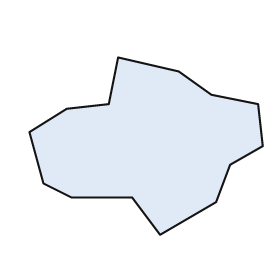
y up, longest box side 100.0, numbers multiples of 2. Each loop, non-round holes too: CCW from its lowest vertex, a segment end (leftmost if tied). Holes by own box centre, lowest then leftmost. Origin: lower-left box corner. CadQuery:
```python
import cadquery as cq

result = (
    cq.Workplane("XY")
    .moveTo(56.0, 0.0)
    .lineTo(80.0, 14.0)
    .lineTo(86.0, 30.0)
    .lineTo(100.0, 38.0)
    .lineTo(98.0, 56.0)
    .lineTo(78.0, 60.0)
    .lineTo(64.0, 70.0)
    .lineTo(38.0, 76.0)
    .lineTo(34.0, 56.0)
    .lineTo(16.0, 54.0)
    .lineTo(0.0, 44.0)
    .lineTo(6.0, 22.0)
    .lineTo(18.0, 16.0)
    .lineTo(44.0, 16.0)
    .close()
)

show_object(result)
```